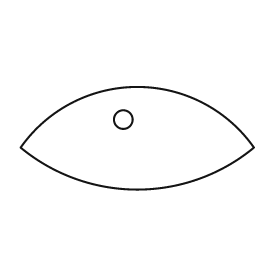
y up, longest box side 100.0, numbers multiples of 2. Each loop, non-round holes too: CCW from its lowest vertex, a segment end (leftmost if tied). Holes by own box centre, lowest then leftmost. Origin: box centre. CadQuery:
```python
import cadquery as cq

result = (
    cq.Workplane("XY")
    .moveTo(-50.0, -4.0)
    .threePointArc((0.0, -22.0), (50.0, -4.0))
    .threePointArc((0.0, 22.0), (-50.0, -4.0))
    .close()
    .moveTo(-6.0, 8.0)
    .circle(4.0)
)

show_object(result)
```